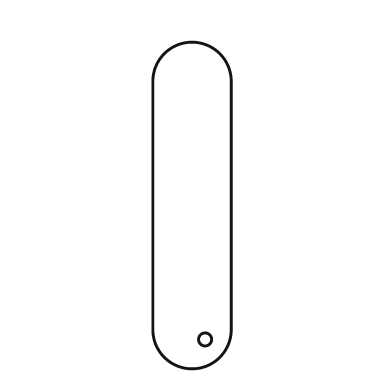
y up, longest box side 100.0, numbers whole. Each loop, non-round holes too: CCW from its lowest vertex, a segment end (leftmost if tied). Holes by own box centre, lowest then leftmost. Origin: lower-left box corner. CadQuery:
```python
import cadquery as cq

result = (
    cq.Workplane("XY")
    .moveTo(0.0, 12.0)
    .threePointArc((12.0, 0.0), (24.0, 12.0))
    .lineTo(24.0, 88.0)
    .threePointArc((12.0, 100.0), (0.0, 88.0))
    .close()
    .moveTo(16.0, 9.0)
    .circle(2.0)
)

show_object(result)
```